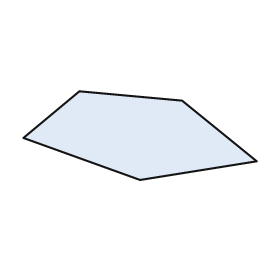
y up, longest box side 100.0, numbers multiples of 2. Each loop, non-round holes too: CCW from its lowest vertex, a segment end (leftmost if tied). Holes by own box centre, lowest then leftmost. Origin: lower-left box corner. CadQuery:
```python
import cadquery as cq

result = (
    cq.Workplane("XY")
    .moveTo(50.0, 0.0)
    .lineTo(100.0, 8.0)
    .lineTo(68.0, 34.0)
    .lineTo(24.0, 38.0)
    .lineTo(0.0, 18.0)
    .close()
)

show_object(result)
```